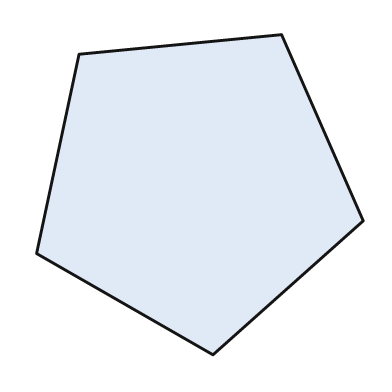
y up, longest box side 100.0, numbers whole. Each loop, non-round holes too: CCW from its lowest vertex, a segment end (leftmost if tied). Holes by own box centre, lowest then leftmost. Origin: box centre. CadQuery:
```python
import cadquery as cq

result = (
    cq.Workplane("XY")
    .moveTo(4.0, -49.0)
    .lineTo(50.0, -8.0)
    .lineTo(25.0, 49.0)
    .lineTo(-37.0, 43.0)
    .lineTo(-50.0, -18.0)
    .close()
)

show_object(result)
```